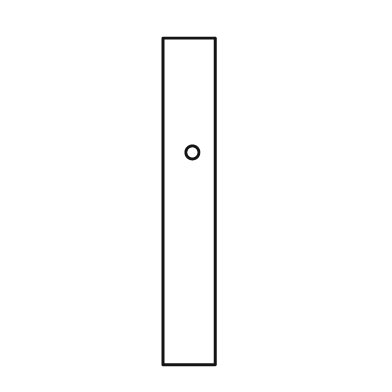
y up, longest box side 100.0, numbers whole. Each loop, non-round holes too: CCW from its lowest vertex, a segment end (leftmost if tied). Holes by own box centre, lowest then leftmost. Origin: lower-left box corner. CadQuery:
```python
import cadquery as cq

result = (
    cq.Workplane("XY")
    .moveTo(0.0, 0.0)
    .lineTo(16.0, 0.0)
    .lineTo(16.0, 100.0)
    .lineTo(0.0, 100.0)
    .close()
    .moveTo(9.0, 65.0)
    .circle(2.0)
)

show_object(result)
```